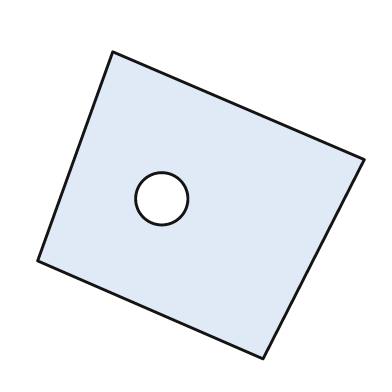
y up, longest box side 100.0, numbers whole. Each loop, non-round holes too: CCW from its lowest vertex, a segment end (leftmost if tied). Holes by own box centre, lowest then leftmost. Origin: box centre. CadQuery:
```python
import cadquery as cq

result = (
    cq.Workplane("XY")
    .moveTo(19.0, -47.0)
    .lineTo(50.0, 14.0)
    .lineTo(-27.0, 47.0)
    .lineTo(-50.0, -17.0)
    .close()
    .moveTo(-12.0, 2.0)
    .circle(8.0)
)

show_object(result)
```